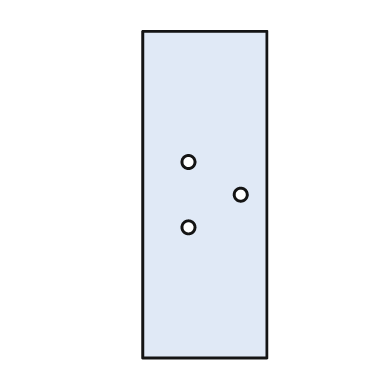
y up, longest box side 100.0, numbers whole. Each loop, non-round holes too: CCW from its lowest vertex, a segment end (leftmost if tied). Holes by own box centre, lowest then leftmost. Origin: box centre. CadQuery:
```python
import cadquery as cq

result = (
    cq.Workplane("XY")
    .moveTo(-19.0, -50.0)
    .lineTo(19.0, -50.0)
    .lineTo(19.0, 50.0)
    .lineTo(-19.0, 50.0)
    .close()
    .moveTo(-5.0, -10.0)
    .circle(2.0)
    .moveTo(11.0, 0.0)
    .circle(2.0)
    .moveTo(-5.0, 10.0)
    .circle(2.0)
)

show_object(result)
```